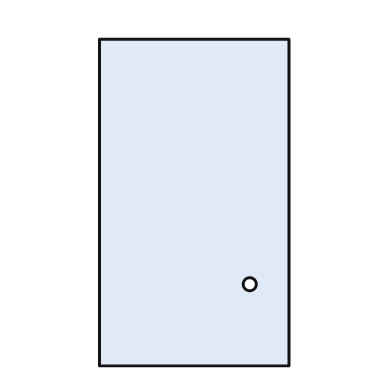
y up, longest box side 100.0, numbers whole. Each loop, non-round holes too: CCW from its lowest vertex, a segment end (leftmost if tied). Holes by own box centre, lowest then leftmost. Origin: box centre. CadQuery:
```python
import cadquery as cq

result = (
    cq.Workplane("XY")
    .moveTo(-29.0, -50.0)
    .lineTo(29.0, -50.0)
    .lineTo(29.0, 50.0)
    .lineTo(-29.0, 50.0)
    .close()
    .moveTo(17.0, -25.0)
    .circle(2.0)
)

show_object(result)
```